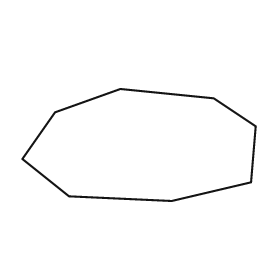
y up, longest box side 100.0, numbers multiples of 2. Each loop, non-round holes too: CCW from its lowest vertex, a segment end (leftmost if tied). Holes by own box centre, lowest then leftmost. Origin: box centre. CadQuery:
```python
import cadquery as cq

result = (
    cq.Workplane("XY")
    .moveTo(14.0, -24.0)
    .lineTo(48.0, -16.0)
    .lineTo(50.0, 8.0)
    .lineTo(32.0, 20.0)
    .lineTo(-8.0, 24.0)
    .lineTo(-36.0, 14.0)
    .lineTo(-50.0, -6.0)
    .lineTo(-30.0, -22.0)
    .close()
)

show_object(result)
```